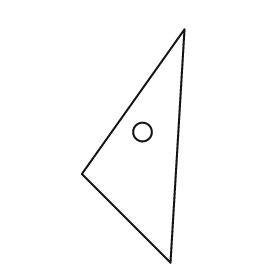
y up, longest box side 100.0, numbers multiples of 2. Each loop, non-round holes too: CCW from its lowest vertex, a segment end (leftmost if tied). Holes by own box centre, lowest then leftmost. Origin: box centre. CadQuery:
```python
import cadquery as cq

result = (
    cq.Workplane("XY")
    .moveTo(16.0, -50.0)
    .lineTo(22.0, 50.0)
    .lineTo(-22.0, -12.0)
    .close()
    .moveTo(4.0, 6.0)
    .circle(4.0)
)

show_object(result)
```